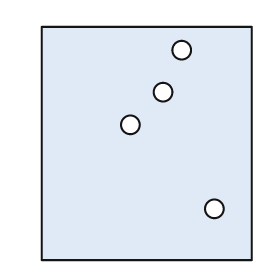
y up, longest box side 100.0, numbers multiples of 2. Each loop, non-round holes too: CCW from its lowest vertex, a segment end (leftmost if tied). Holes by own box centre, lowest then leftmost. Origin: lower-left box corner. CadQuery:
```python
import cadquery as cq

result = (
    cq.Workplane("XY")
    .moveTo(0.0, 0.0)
    .lineTo(90.0, 0.0)
    .lineTo(90.0, 100.0)
    .lineTo(0.0, 100.0)
    .close()
    .moveTo(74.0, 22.0)
    .circle(4.0)
    .moveTo(38.0, 58.0)
    .circle(4.0)
    .moveTo(52.0, 72.0)
    .circle(4.0)
    .moveTo(60.0, 90.0)
    .circle(4.0)
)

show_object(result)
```